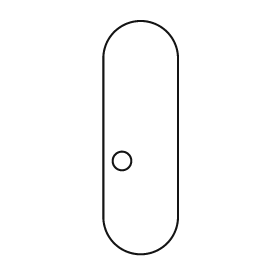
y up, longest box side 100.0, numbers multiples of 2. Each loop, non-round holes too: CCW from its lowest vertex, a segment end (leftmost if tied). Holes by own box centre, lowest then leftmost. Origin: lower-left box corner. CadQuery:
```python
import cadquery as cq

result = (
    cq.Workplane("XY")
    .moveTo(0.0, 16.0)
    .threePointArc((16.0, 0.0), (32.0, 16.0))
    .lineTo(32.0, 84.0)
    .threePointArc((16.0, 100.0), (0.0, 84.0))
    .close()
    .moveTo(8.0, 40.0)
    .circle(4.0)
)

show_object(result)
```